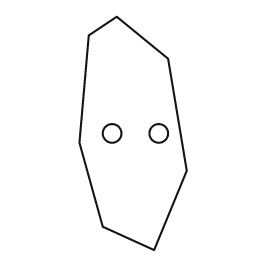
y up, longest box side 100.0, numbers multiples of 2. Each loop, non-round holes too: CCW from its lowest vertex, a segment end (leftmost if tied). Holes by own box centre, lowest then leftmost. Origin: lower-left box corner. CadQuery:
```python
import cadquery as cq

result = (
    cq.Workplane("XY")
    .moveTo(32.0, 0.0)
    .lineTo(46.0, 34.0)
    .lineTo(38.0, 82.0)
    .lineTo(16.0, 100.0)
    .lineTo(4.0, 92.0)
    .lineTo(0.0, 46.0)
    .lineTo(10.0, 10.0)
    .close()
    .moveTo(14.0, 50.0)
    .circle(4.0)
    .moveTo(34.0, 50.0)
    .circle(4.0)
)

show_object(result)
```